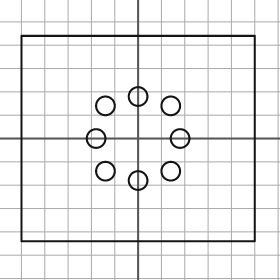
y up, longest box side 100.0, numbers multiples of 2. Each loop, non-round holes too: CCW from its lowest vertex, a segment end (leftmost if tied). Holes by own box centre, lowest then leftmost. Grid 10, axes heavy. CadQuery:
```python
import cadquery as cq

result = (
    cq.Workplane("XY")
    .moveTo(-50.0, -44.0)
    .lineTo(50.0, -44.0)
    .lineTo(50.0, 44.0)
    .lineTo(-50.0, 44.0)
    .close()
    .moveTo(0.0, -18.0)
    .circle(4.0)
    .moveTo(-14.0, -14.0)
    .circle(4.0)
    .moveTo(14.0, -14.0)
    .circle(4.0)
    .moveTo(-18.0, 0.0)
    .circle(4.0)
    .moveTo(18.0, 0.0)
    .circle(4.0)
    .moveTo(-14.0, 14.0)
    .circle(4.0)
    .moveTo(14.0, 14.0)
    .circle(4.0)
    .moveTo(0.0, 18.0)
    .circle(4.0)
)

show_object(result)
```